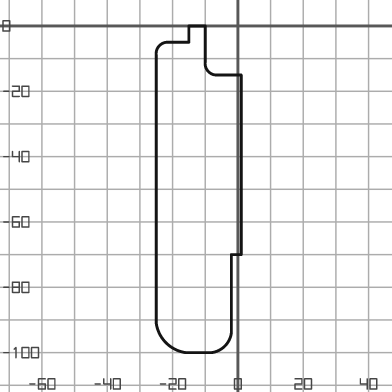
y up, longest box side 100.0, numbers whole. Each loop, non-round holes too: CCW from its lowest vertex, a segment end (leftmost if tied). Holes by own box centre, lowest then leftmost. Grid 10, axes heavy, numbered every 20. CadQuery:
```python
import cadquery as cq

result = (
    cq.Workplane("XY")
    .moveTo(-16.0, -100.0)
    .lineTo(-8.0, -100.0)
    .threePointArc((-4.0, -98.0), (-2.0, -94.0))
    .lineTo(-2.0, -70.0)
    .lineTo(1.0, -70.0)
    .lineTo(1.0, -15.0)
    .lineTo(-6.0, -15.0)
    .threePointArc((-9.0, -14.0), (-10.0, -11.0))
    .lineTo(-10.0, 0.0)
    .lineTo(-15.0, 0.0)
    .lineTo(-15.0, -5.0)
    .lineTo(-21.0, -5.0)
    .threePointArc((-24.0, -6.0), (-25.0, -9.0))
    .lineTo(-25.0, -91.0)
    .threePointArc((-22.0, -97.0), (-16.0, -100.0))
    .close()
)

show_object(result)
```